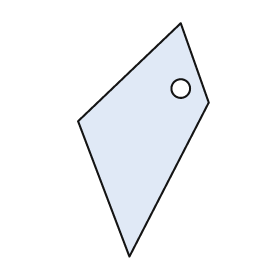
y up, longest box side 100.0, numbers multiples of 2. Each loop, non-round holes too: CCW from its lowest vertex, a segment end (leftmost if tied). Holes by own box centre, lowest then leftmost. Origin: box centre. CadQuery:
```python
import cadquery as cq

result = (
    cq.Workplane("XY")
    .moveTo(-6.0, -50.0)
    .lineTo(28.0, 16.0)
    .lineTo(16.0, 50.0)
    .lineTo(-28.0, 8.0)
    .close()
    .moveTo(16.0, 22.0)
    .circle(4.0)
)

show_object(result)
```